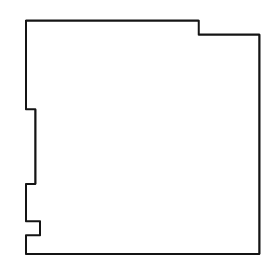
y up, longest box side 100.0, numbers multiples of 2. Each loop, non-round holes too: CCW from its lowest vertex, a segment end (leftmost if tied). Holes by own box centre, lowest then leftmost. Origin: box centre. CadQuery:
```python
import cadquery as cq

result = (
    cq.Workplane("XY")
    .moveTo(-50.0, -50.0)
    .lineTo(50.0, -50.0)
    .lineTo(50.0, 44.0)
    .lineTo(24.0, 44.0)
    .lineTo(24.0, 50.0)
    .lineTo(-50.0, 50.0)
    .lineTo(-50.0, 12.0)
    .lineTo(-46.0, 12.0)
    .lineTo(-46.0, -20.0)
    .lineTo(-50.0, -20.0)
    .lineTo(-50.0, -36.0)
    .lineTo(-44.0, -36.0)
    .lineTo(-44.0, -42.0)
    .lineTo(-50.0, -42.0)
    .close()
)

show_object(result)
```